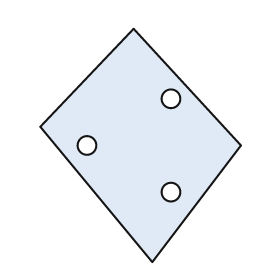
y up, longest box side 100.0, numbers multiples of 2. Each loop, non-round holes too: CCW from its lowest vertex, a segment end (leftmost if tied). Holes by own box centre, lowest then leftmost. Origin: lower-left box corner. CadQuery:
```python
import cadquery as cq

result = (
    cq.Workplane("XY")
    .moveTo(48.0, 0.0)
    .lineTo(86.0, 50.0)
    .lineTo(40.0, 100.0)
    .lineTo(0.0, 58.0)
    .close()
    .moveTo(56.0, 30.0)
    .circle(4.0)
    .moveTo(20.0, 50.0)
    .circle(4.0)
    .moveTo(56.0, 70.0)
    .circle(4.0)
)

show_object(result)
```